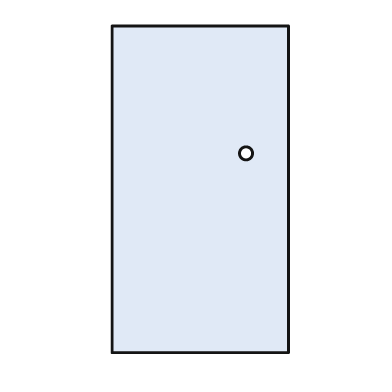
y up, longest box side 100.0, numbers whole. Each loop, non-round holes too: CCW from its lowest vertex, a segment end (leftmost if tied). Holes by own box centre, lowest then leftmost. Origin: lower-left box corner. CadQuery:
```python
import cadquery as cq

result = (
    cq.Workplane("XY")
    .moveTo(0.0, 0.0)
    .lineTo(54.0, 0.0)
    .lineTo(54.0, 100.0)
    .lineTo(0.0, 100.0)
    .close()
    .moveTo(41.0, 61.0)
    .circle(2.0)
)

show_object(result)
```